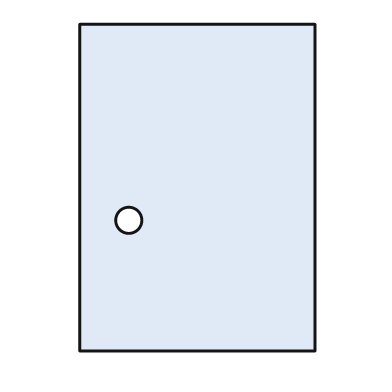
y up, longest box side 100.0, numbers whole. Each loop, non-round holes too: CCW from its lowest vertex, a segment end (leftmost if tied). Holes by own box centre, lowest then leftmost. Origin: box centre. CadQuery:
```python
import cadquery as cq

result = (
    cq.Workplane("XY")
    .moveTo(-36.0, -50.0)
    .lineTo(36.0, -50.0)
    .lineTo(36.0, 50.0)
    .lineTo(-36.0, 50.0)
    .close()
    .moveTo(-21.0, -10.0)
    .circle(4.0)
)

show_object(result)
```